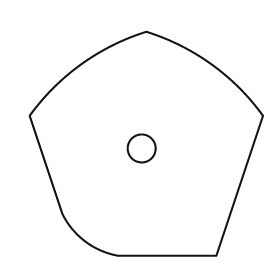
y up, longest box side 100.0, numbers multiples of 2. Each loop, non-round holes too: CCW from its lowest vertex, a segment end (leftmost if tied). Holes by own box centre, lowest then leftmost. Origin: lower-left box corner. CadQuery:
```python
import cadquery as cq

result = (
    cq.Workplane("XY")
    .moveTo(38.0, 0.0)
    .lineTo(80.0, 0.0)
    .lineTo(100.0, 60.0)
    .threePointArc((78.0, 82.0), (50.0, 96.0))
    .threePointArc((22.0, 82.0), (0.0, 60.0))
    .lineTo(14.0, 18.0)
    .threePointArc((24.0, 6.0), (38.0, 0.0))
    .close()
    .moveTo(48.0, 46.0)
    .circle(6.0)
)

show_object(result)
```